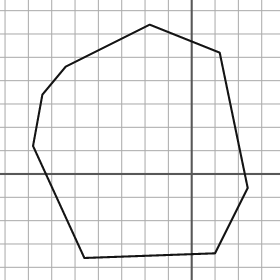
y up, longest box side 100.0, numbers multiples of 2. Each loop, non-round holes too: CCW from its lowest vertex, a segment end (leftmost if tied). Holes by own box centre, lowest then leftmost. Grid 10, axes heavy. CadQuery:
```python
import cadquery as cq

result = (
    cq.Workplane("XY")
    .moveTo(-46.0, -36.0)
    .lineTo(10.0, -34.0)
    .lineTo(24.0, -6.0)
    .lineTo(12.0, 52.0)
    .lineTo(-18.0, 64.0)
    .lineTo(-54.0, 46.0)
    .lineTo(-64.0, 34.0)
    .lineTo(-68.0, 12.0)
    .close()
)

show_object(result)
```